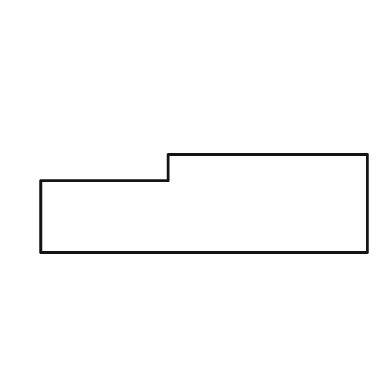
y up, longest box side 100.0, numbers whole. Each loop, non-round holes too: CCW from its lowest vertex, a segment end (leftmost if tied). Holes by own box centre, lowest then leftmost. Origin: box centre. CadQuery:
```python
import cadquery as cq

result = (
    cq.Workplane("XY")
    .moveTo(-50.0, -15.0)
    .lineTo(50.0, -15.0)
    .lineTo(50.0, 15.0)
    .lineTo(-11.0, 15.0)
    .lineTo(-11.0, 7.0)
    .lineTo(-50.0, 7.0)
    .close()
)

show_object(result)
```